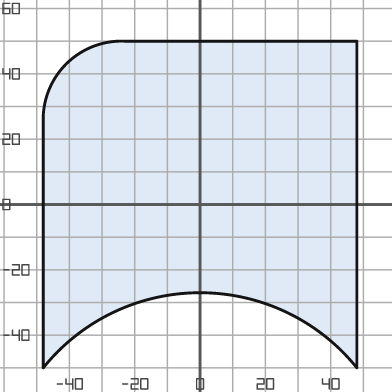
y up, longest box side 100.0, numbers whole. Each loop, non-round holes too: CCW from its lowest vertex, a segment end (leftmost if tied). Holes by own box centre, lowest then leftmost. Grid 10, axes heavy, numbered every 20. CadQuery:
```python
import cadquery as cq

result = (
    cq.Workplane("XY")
    .moveTo(-48.0, -50.0)
    .threePointArc((0.0, -27.0), (48.0, -50.0))
    .lineTo(48.0, 50.0)
    .lineTo(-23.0, 50.0)
    .threePointArc((-41.0, 43.0), (-48.0, 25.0))
    .close()
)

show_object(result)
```